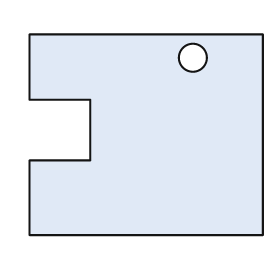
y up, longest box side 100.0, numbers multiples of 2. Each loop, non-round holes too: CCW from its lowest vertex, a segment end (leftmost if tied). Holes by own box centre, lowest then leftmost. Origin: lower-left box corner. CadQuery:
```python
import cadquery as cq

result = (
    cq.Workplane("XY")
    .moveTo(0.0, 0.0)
    .lineTo(100.0, 0.0)
    .lineTo(100.0, 86.0)
    .lineTo(0.0, 86.0)
    .lineTo(0.0, 58.0)
    .lineTo(26.0, 58.0)
    .lineTo(26.0, 32.0)
    .lineTo(0.0, 32.0)
    .close()
    .moveTo(70.0, 76.0)
    .circle(6.0)
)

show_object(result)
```